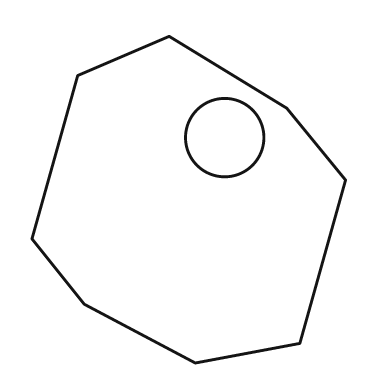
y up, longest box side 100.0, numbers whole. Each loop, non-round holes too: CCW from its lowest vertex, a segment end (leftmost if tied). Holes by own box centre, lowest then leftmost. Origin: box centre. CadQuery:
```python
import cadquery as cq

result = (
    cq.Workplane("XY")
    .moveTo(2.0, -50.0)
    .lineTo(34.0, -44.0)
    .lineTo(48.0, 6.0)
    .lineTo(30.0, 28.0)
    .lineTo(-6.0, 50.0)
    .lineTo(-34.0, 38.0)
    .lineTo(-48.0, -12.0)
    .lineTo(-32.0, -32.0)
    .close()
    .moveTo(11.0, 19.0)
    .circle(12.0)
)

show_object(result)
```